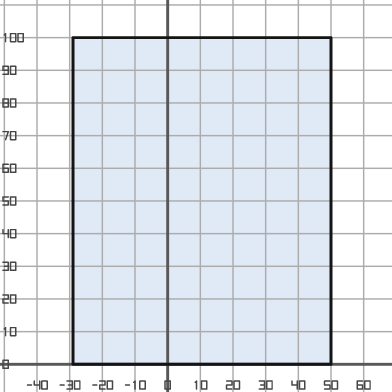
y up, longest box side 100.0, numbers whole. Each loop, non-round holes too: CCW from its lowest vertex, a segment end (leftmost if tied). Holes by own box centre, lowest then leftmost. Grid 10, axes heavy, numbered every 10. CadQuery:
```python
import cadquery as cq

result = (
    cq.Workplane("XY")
    .moveTo(-29.0, 0.0)
    .lineTo(50.0, 0.0)
    .lineTo(50.0, 100.0)
    .lineTo(-29.0, 100.0)
    .close()
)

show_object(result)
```